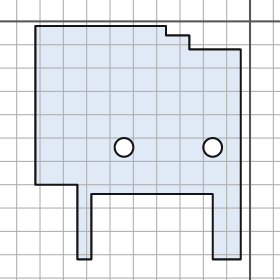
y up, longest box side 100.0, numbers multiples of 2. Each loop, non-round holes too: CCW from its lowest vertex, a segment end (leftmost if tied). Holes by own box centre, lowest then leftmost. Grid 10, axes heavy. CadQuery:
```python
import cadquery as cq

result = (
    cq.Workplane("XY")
    .moveTo(-74.0, -102.0)
    .lineTo(-68.0, -102.0)
    .lineTo(-68.0, -74.0)
    .lineTo(-16.0, -74.0)
    .lineTo(-16.0, -102.0)
    .lineTo(-4.0, -102.0)
    .lineTo(-4.0, -12.0)
    .lineTo(-26.0, -12.0)
    .lineTo(-26.0, -6.0)
    .lineTo(-36.0, -6.0)
    .lineTo(-36.0, -2.0)
    .lineTo(-92.0, -2.0)
    .lineTo(-92.0, -70.0)
    .lineTo(-74.0, -70.0)
    .close()
    .moveTo(-54.0, -54.0)
    .circle(4.0)
    .moveTo(-16.0, -54.0)
    .circle(4.0)
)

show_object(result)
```